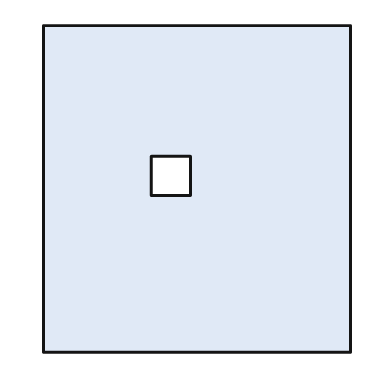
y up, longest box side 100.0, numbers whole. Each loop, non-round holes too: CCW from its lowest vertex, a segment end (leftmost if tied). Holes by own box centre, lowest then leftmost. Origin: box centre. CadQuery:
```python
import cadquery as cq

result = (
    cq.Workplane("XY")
    .moveTo(-47.0, -50.0)
    .lineTo(47.0, -50.0)
    .lineTo(47.0, 50.0)
    .lineTo(-47.0, 50.0)
    .close()
    .moveTo(-14.0, -2.0)
    .lineTo(-2.0, -2.0)
    .lineTo(-2.0, 10.0)
    .lineTo(-14.0, 10.0)
    .close()
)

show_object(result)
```